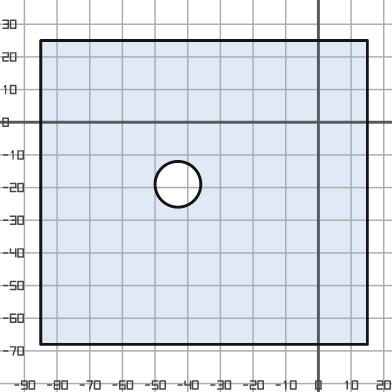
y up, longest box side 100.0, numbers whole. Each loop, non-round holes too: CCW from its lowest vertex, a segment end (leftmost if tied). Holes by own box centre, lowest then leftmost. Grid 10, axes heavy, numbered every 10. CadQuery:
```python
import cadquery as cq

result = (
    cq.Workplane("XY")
    .moveTo(-85.0, -68.0)
    .lineTo(15.0, -68.0)
    .lineTo(15.0, 25.0)
    .lineTo(-85.0, 25.0)
    .close()
    .moveTo(-43.0, -19.0)
    .circle(7.0)
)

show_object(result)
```